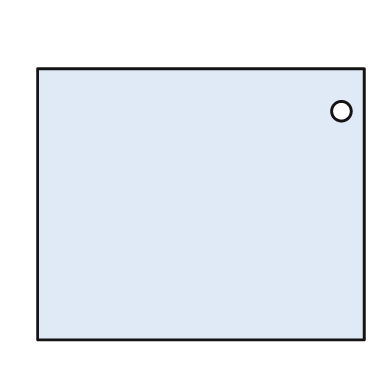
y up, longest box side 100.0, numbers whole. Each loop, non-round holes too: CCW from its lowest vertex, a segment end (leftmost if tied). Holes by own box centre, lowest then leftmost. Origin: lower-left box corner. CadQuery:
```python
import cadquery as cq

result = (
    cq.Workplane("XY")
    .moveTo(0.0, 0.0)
    .lineTo(100.0, 0.0)
    .lineTo(100.0, 83.0)
    .lineTo(0.0, 83.0)
    .close()
    .moveTo(93.0, 70.0)
    .circle(3.0)
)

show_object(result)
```